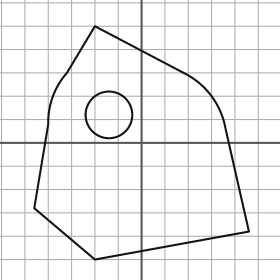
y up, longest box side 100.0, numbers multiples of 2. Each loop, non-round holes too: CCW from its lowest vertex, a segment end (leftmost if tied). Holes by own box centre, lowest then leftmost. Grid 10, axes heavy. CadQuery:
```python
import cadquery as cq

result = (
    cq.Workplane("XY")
    .moveTo(-20.0, -50.0)
    .lineTo(46.0, -38.0)
    .lineTo(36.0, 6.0)
    .threePointArc((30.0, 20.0), (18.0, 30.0))
    .lineTo(-20.0, 50.0)
    .lineTo(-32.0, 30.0)
    .threePointArc((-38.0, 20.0), (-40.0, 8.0))
    .lineTo(-46.0, -28.0)
    .close()
    .moveTo(-14.0, 12.0)
    .circle(10.0)
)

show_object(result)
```